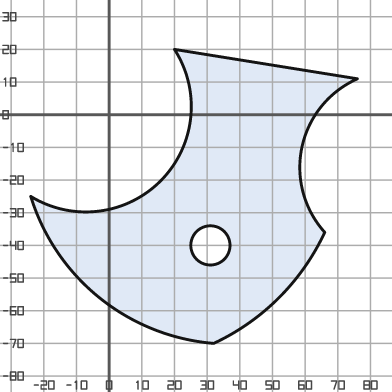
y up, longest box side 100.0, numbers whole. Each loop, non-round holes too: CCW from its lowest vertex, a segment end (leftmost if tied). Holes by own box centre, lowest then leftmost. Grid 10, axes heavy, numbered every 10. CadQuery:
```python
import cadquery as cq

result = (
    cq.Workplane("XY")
    .moveTo(32.0, -70.0)
    .threePointArc((52.0, -56.0), (66.0, -36.0))
    .threePointArc((59.0, -10.0), (76.0, 11.0))
    .lineTo(20.0, 20.0)
    .threePointArc((16.0, -20.0), (-24.0, -25.0))
    .threePointArc((-3.0, -56.0), (32.0, -70.0))
    .close()
    .moveTo(31.0, -40.0)
    .circle(6.0)
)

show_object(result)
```